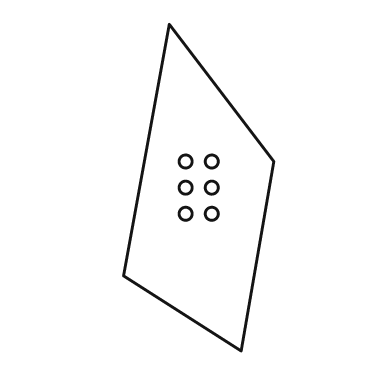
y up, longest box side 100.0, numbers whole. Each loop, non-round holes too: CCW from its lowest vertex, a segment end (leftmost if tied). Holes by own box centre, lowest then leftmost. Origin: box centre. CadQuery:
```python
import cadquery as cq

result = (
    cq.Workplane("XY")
    .moveTo(13.0, -50.0)
    .lineTo(23.0, 8.0)
    .lineTo(-9.0, 50.0)
    .lineTo(-23.0, -27.0)
    .close()
    .moveTo(-4.0, -8.0)
    .circle(2.0)
    .moveTo(4.0, -8.0)
    .circle(2.0)
    .moveTo(-4.0, 0.0)
    .circle(2.0)
    .moveTo(4.0, 0.0)
    .circle(2.0)
    .moveTo(-4.0, 8.0)
    .circle(2.0)
    .moveTo(4.0, 8.0)
    .circle(2.0)
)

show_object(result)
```